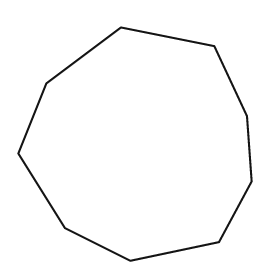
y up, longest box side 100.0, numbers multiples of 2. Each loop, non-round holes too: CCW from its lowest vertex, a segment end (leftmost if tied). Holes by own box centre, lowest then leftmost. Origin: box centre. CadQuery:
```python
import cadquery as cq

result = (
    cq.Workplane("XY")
    .moveTo(-2.0, -50.0)
    .lineTo(36.0, -42.0)
    .lineTo(50.0, -16.0)
    .lineTo(48.0, 12.0)
    .lineTo(34.0, 42.0)
    .lineTo(-6.0, 50.0)
    .lineTo(-38.0, 26.0)
    .lineTo(-50.0, -4.0)
    .lineTo(-30.0, -36.0)
    .close()
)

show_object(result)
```